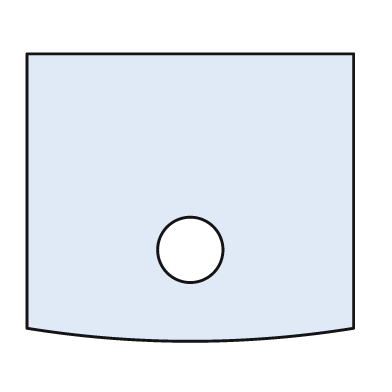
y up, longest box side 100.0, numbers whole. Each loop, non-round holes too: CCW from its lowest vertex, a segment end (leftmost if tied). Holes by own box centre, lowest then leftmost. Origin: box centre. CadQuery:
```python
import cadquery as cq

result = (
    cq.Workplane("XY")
    .moveTo(-50.0, -40.0)
    .threePointArc((0.0, -44.0), (50.0, -40.0))
    .lineTo(50.0, 44.0)
    .lineTo(-50.0, 44.0)
    .close()
    .moveTo(0.0, -16.0)
    .circle(10.0)
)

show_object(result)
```